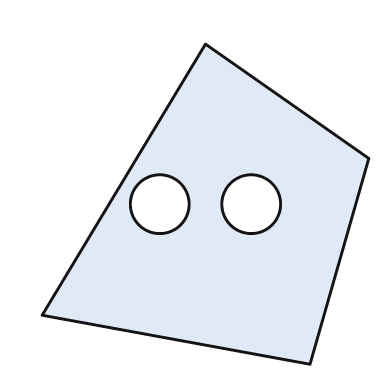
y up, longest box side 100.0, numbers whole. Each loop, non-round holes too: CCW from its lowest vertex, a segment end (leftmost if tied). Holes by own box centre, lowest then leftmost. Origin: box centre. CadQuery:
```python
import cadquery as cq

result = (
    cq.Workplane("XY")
    .moveTo(32.0, -49.0)
    .lineTo(50.0, 14.0)
    .lineTo(0.0, 49.0)
    .lineTo(-50.0, -34.0)
    .close()
    .moveTo(-14.0, 0.0)
    .circle(9.0)
    .moveTo(14.0, 0.0)
    .circle(9.0)
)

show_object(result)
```